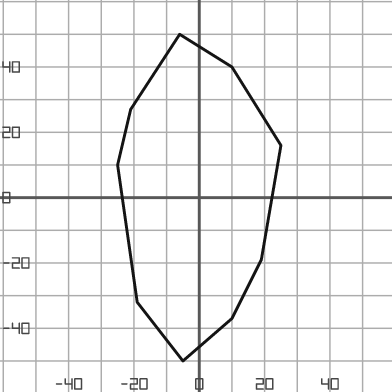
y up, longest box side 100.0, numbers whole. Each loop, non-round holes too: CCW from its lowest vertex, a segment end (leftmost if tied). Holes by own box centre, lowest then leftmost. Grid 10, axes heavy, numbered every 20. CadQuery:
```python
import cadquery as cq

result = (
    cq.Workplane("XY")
    .moveTo(-5.0, -50.0)
    .lineTo(10.0, -37.0)
    .lineTo(19.0, -19.0)
    .lineTo(25.0, 16.0)
    .lineTo(10.0, 40.0)
    .lineTo(-6.0, 50.0)
    .lineTo(-21.0, 27.0)
    .lineTo(-25.0, 10.0)
    .lineTo(-19.0, -32.0)
    .close()
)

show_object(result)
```